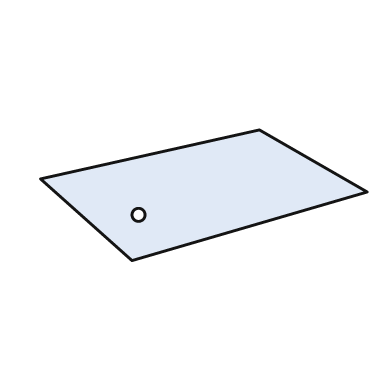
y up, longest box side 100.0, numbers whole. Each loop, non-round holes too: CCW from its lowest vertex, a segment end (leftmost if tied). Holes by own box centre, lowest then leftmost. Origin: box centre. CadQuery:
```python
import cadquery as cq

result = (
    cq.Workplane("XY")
    .moveTo(-22.0, -20.0)
    .lineTo(50.0, 1.0)
    .lineTo(17.0, 20.0)
    .lineTo(-50.0, 5.0)
    .close()
    .moveTo(-20.0, -6.0)
    .circle(2.0)
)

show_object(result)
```